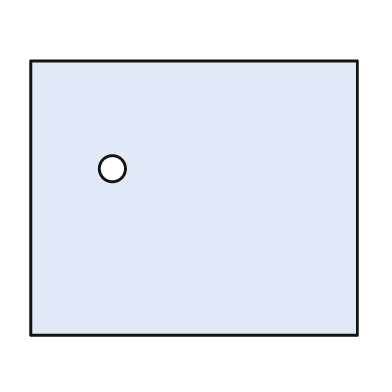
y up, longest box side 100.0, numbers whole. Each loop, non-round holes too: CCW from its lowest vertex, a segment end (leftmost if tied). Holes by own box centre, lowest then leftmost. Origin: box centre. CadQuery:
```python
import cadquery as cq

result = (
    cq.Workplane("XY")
    .moveTo(-50.0, -42.0)
    .lineTo(50.0, -42.0)
    .lineTo(50.0, 42.0)
    .lineTo(-50.0, 42.0)
    .close()
    .moveTo(-25.0, 9.0)
    .circle(4.0)
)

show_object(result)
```